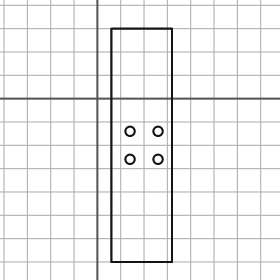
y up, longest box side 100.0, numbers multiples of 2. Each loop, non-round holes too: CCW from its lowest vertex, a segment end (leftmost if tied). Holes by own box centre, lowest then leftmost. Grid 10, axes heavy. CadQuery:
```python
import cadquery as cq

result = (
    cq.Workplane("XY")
    .moveTo(6.0, -70.0)
    .lineTo(32.0, -70.0)
    .lineTo(32.0, 30.0)
    .lineTo(6.0, 30.0)
    .close()
    .moveTo(14.0, -26.0)
    .circle(2.0)
    .moveTo(26.0, -26.0)
    .circle(2.0)
    .moveTo(14.0, -14.0)
    .circle(2.0)
    .moveTo(26.0, -14.0)
    .circle(2.0)
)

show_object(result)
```